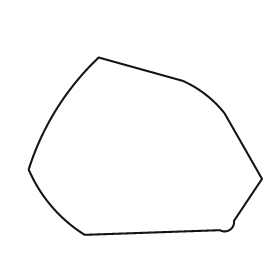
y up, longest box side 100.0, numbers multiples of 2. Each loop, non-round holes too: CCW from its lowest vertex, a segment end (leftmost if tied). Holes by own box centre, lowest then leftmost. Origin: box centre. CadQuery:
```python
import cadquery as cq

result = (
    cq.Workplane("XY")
    .moveTo(-26.0, -38.0)
    .lineTo(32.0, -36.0)
    .threePointArc((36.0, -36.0), (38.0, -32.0))
    .lineTo(50.0, -14.0)
    .lineTo(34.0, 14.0)
    .threePointArc((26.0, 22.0), (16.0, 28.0))
    .lineTo(-20.0, 38.0)
    .threePointArc((-38.0, 16.0), (-50.0, -10.0))
    .threePointArc((-40.0, -26.0), (-26.0, -38.0))
    .close()
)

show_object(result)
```